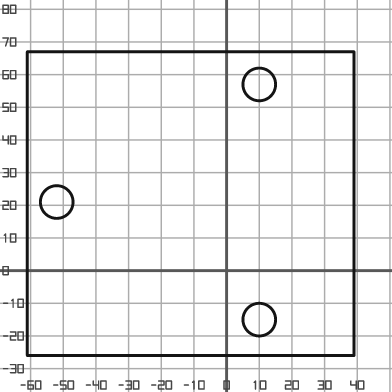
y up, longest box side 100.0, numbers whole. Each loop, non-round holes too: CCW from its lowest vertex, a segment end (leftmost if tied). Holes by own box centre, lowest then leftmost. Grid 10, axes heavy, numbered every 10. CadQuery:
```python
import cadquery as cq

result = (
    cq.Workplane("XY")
    .moveTo(-61.0, -26.0)
    .lineTo(39.0, -26.0)
    .lineTo(39.0, 67.0)
    .lineTo(-61.0, 67.0)
    .close()
    .moveTo(10.0, -15.0)
    .circle(5.0)
    .moveTo(-52.0, 21.0)
    .circle(5.0)
    .moveTo(10.0, 57.0)
    .circle(5.0)
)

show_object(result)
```